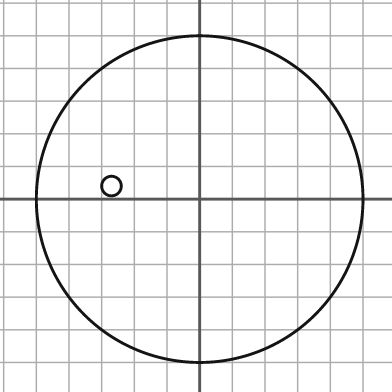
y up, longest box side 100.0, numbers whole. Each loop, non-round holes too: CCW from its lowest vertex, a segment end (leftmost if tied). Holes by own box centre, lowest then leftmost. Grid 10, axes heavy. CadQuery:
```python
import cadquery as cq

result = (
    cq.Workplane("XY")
    .moveTo(0.0, 0.0)
    .circle(50.0)
    .moveTo(-27.0, 4.0)
    .circle(3.0)
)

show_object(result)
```